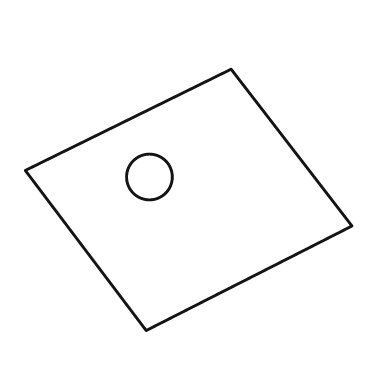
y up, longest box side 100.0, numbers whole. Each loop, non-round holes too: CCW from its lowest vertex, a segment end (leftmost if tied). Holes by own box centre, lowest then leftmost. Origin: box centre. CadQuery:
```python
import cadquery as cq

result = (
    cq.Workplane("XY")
    .moveTo(-13.0, -40.0)
    .lineTo(50.0, -8.0)
    .lineTo(13.0, 40.0)
    .lineTo(-50.0, 9.0)
    .close()
    .moveTo(-12.0, 7.0)
    .circle(7.0)
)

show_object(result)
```